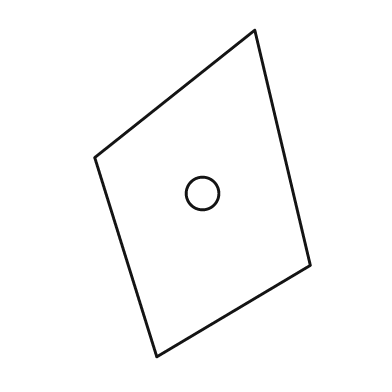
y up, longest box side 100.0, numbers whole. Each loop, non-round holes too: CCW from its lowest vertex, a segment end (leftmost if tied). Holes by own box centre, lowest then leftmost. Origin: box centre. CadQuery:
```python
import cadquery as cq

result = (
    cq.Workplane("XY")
    .moveTo(-14.0, -50.0)
    .lineTo(33.0, -22.0)
    .lineTo(16.0, 50.0)
    .lineTo(-33.0, 11.0)
    .close()
    .moveTo(0.0, 0.0)
    .circle(5.0)
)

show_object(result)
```